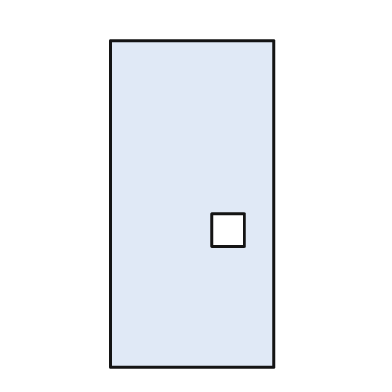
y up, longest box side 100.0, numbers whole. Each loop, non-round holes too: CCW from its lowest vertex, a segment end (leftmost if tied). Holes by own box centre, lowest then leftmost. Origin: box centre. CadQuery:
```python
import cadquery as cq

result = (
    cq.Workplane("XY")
    .moveTo(-25.0, -50.0)
    .lineTo(25.0, -50.0)
    .lineTo(25.0, 50.0)
    .lineTo(-25.0, 50.0)
    .close()
    .moveTo(6.0, -13.0)
    .lineTo(16.0, -13.0)
    .lineTo(16.0, -3.0)
    .lineTo(6.0, -3.0)
    .close()
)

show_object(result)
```